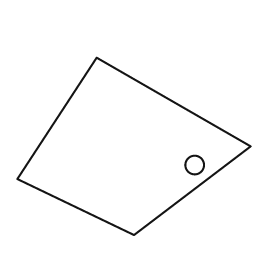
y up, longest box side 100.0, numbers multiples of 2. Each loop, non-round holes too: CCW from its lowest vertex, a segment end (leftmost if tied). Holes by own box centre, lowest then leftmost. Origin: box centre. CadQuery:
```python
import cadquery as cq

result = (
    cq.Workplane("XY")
    .moveTo(0.0, -38.0)
    .lineTo(50.0, 0.0)
    .lineTo(-16.0, 38.0)
    .lineTo(-50.0, -14.0)
    .close()
    .moveTo(26.0, -8.0)
    .circle(4.0)
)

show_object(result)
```